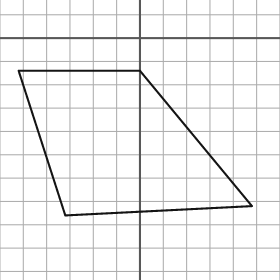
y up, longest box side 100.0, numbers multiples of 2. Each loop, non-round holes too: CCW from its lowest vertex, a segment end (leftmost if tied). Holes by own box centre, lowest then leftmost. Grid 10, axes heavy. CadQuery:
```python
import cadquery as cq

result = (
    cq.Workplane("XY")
    .moveTo(-32.0, -76.0)
    .lineTo(48.0, -72.0)
    .lineTo(0.0, -14.0)
    .lineTo(-52.0, -14.0)
    .close()
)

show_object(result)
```